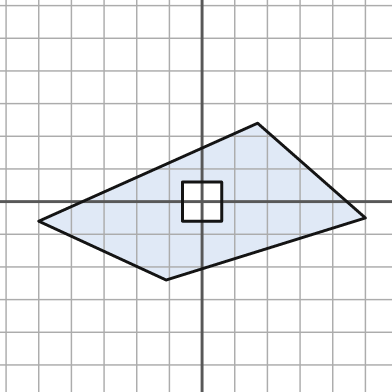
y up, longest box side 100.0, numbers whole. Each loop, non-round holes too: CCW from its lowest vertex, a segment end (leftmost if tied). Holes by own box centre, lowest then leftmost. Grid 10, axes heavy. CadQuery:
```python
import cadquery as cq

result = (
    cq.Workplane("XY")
    .moveTo(-11.0, -24.0)
    .lineTo(50.0, -5.0)
    .lineTo(17.0, 24.0)
    .lineTo(-50.0, -6.0)
    .close()
    .moveTo(-6.0, -6.0)
    .lineTo(6.0, -6.0)
    .lineTo(6.0, 6.0)
    .lineTo(-6.0, 6.0)
    .close()
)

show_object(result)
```